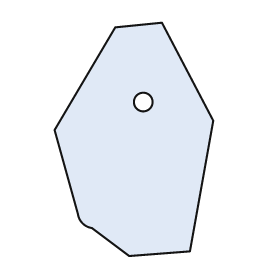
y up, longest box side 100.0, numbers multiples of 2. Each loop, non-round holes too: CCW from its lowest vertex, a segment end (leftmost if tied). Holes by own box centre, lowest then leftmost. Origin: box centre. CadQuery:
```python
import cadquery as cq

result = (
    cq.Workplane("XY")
    .moveTo(-2.0, -50.0)
    .lineTo(24.0, -48.0)
    .lineTo(34.0, 8.0)
    .lineTo(12.0, 50.0)
    .lineTo(-8.0, 48.0)
    .lineTo(-34.0, 4.0)
    .lineTo(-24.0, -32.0)
    .threePointArc((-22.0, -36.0), (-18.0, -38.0))
    .close()
    .moveTo(4.0, 16.0)
    .circle(4.0)
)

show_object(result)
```